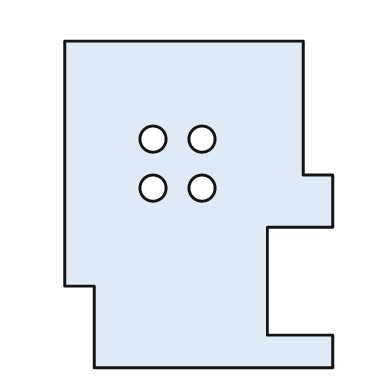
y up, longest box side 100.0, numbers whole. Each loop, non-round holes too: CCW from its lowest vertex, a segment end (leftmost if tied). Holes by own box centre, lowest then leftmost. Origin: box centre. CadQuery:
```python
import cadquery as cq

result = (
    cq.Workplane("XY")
    .moveTo(-32.0, -50.0)
    .lineTo(41.0, -50.0)
    .lineTo(41.0, -40.0)
    .lineTo(21.0, -40.0)
    .lineTo(21.0, -7.0)
    .lineTo(41.0, -7.0)
    .lineTo(41.0, 9.0)
    .lineTo(32.0, 9.0)
    .lineTo(32.0, 50.0)
    .lineTo(-41.0, 50.0)
    .lineTo(-41.0, -25.0)
    .lineTo(-32.0, -25.0)
    .close()
    .moveTo(-14.0, 5.0)
    .circle(4.0)
    .moveTo(1.0, 5.0)
    .circle(4.0)
    .moveTo(-14.0, 20.0)
    .circle(4.0)
    .moveTo(1.0, 20.0)
    .circle(4.0)
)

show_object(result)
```